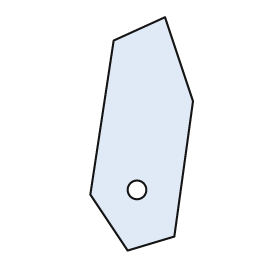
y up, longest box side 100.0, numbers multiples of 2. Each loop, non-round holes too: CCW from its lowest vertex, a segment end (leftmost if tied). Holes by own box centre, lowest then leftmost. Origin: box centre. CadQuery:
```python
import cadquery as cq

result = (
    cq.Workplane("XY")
    .moveTo(-6.0, -50.0)
    .lineTo(14.0, -44.0)
    .lineTo(22.0, 14.0)
    .lineTo(10.0, 50.0)
    .lineTo(-12.0, 40.0)
    .lineTo(-22.0, -26.0)
    .close()
    .moveTo(-2.0, -24.0)
    .circle(4.0)
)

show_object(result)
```